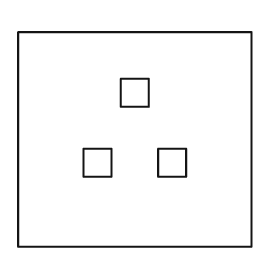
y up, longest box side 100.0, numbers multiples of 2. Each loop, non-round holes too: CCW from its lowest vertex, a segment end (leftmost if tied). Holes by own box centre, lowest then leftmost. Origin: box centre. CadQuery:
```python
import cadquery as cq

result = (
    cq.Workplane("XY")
    .moveTo(-50.0, -46.0)
    .lineTo(50.0, -46.0)
    .lineTo(50.0, 46.0)
    .lineTo(-50.0, 46.0)
    .close()
    .moveTo(-22.0, -16.0)
    .lineTo(-10.0, -16.0)
    .lineTo(-10.0, -4.0)
    .lineTo(-22.0, -4.0)
    .close()
    .moveTo(10.0, -16.0)
    .lineTo(22.0, -16.0)
    .lineTo(22.0, -4.0)
    .lineTo(10.0, -4.0)
    .close()
    .moveTo(-6.0, 14.0)
    .lineTo(6.0, 14.0)
    .lineTo(6.0, 26.0)
    .lineTo(-6.0, 26.0)
    .close()
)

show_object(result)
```